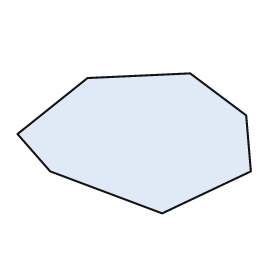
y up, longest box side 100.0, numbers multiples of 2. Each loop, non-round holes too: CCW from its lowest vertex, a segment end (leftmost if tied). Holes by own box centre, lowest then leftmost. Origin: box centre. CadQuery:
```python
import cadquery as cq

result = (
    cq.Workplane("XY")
    .moveTo(12.0, -30.0)
    .lineTo(50.0, -12.0)
    .lineTo(48.0, 12.0)
    .lineTo(24.0, 30.0)
    .lineTo(-20.0, 28.0)
    .lineTo(-50.0, 4.0)
    .lineTo(-36.0, -12.0)
    .close()
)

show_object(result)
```